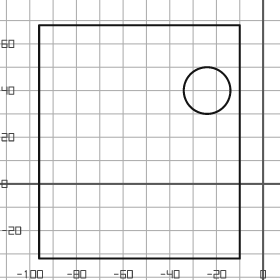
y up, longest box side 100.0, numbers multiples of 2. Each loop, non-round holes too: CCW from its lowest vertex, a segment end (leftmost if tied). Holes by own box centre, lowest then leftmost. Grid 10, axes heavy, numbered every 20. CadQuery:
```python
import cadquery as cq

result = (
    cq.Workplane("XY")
    .moveTo(-96.0, -32.0)
    .lineTo(-10.0, -32.0)
    .lineTo(-10.0, 68.0)
    .lineTo(-96.0, 68.0)
    .close()
    .moveTo(-24.0, 40.0)
    .circle(10.0)
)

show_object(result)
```